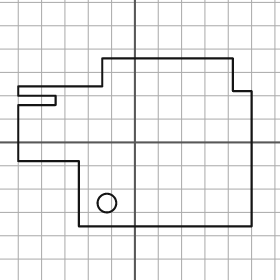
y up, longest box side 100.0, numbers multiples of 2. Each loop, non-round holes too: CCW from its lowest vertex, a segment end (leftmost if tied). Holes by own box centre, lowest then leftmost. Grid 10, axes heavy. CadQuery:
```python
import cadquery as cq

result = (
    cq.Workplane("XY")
    .moveTo(-24.0, -36.0)
    .lineTo(50.0, -36.0)
    .lineTo(50.0, 22.0)
    .lineTo(42.0, 22.0)
    .lineTo(42.0, 36.0)
    .lineTo(-14.0, 36.0)
    .lineTo(-14.0, 24.0)
    .lineTo(-50.0, 24.0)
    .lineTo(-50.0, 20.0)
    .lineTo(-34.0, 20.0)
    .lineTo(-34.0, 16.0)
    .lineTo(-50.0, 16.0)
    .lineTo(-50.0, -8.0)
    .lineTo(-24.0, -8.0)
    .close()
    .moveTo(-12.0, -26.0)
    .circle(4.0)
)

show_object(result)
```